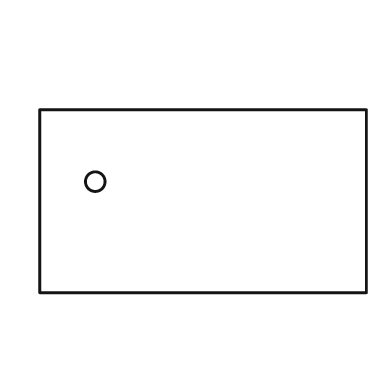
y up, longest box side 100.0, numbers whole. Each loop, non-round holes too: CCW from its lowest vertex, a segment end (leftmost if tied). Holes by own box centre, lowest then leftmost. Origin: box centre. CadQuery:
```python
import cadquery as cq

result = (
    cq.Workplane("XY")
    .moveTo(-50.0, -28.0)
    .lineTo(50.0, -28.0)
    .lineTo(50.0, 28.0)
    .lineTo(-50.0, 28.0)
    .close()
    .moveTo(-33.0, 6.0)
    .circle(3.0)
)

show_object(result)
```